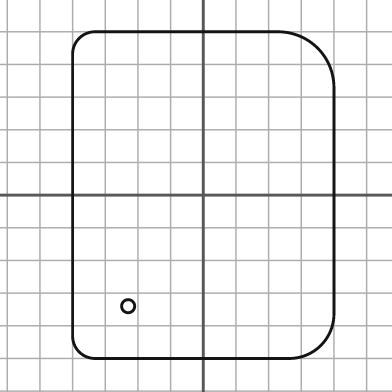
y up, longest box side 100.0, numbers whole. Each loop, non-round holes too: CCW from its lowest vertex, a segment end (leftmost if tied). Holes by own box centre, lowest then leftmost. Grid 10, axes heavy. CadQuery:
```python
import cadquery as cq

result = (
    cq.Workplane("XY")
    .moveTo(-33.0, -50.0)
    .lineTo(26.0, -50.0)
    .threePointArc((36.0, -46.0), (40.0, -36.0))
    .lineTo(40.0, 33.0)
    .threePointArc((35.0, 45.0), (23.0, 50.0))
    .lineTo(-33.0, 50.0)
    .threePointArc((-38.0, 48.0), (-40.0, 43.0))
    .lineTo(-40.0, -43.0)
    .threePointArc((-38.0, -48.0), (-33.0, -50.0))
    .close()
    .moveTo(-23.0, -34.0)
    .circle(2.0)
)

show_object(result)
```